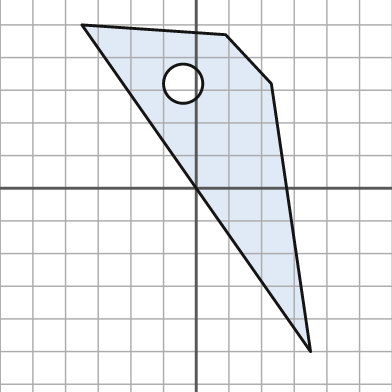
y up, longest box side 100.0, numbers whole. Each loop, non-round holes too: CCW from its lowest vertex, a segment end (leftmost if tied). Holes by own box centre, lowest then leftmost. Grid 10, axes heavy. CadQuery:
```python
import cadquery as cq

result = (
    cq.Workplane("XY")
    .moveTo(35.0, -50.0)
    .lineTo(23.0, 32.0)
    .lineTo(9.0, 47.0)
    .lineTo(-35.0, 50.0)
    .close()
    .moveTo(-4.0, 32.0)
    .circle(6.0)
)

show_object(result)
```